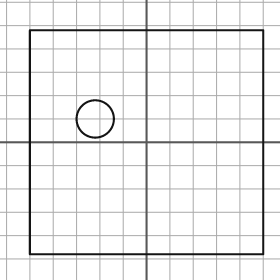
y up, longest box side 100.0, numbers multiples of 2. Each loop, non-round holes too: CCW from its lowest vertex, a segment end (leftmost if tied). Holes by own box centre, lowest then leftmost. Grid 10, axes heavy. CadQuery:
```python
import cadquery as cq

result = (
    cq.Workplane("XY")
    .moveTo(-50.0, -48.0)
    .lineTo(50.0, -48.0)
    .lineTo(50.0, 48.0)
    .lineTo(-50.0, 48.0)
    .close()
    .moveTo(-22.0, 10.0)
    .circle(8.0)
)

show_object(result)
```